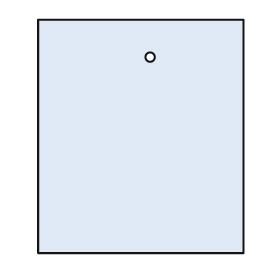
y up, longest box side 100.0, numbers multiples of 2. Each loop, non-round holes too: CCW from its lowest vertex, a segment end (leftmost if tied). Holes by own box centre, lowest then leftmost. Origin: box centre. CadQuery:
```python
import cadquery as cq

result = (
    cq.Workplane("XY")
    .moveTo(-44.0, -50.0)
    .lineTo(44.0, -50.0)
    .lineTo(44.0, 50.0)
    .lineTo(-44.0, 50.0)
    .close()
    .moveTo(4.0, 34.0)
    .circle(2.0)
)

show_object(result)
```